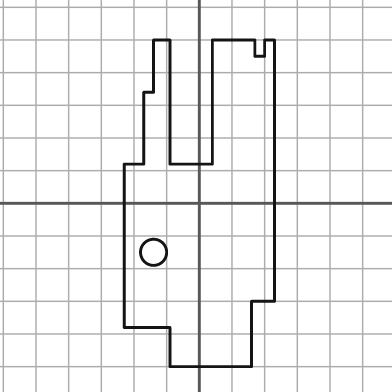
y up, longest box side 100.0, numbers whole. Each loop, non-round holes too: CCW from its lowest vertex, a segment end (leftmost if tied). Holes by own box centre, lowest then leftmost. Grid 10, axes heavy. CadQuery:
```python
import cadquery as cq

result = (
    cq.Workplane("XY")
    .moveTo(-9.0, -50.0)
    .lineTo(16.0, -50.0)
    .lineTo(16.0, -30.0)
    .lineTo(23.0, -30.0)
    .lineTo(23.0, 50.0)
    .lineTo(20.0, 50.0)
    .lineTo(20.0, 45.0)
    .lineTo(17.0, 45.0)
    .lineTo(17.0, 50.0)
    .lineTo(4.0, 50.0)
    .lineTo(4.0, 12.0)
    .lineTo(-9.0, 12.0)
    .lineTo(-9.0, 50.0)
    .lineTo(-14.0, 50.0)
    .lineTo(-14.0, 34.0)
    .lineTo(-17.0, 34.0)
    .lineTo(-17.0, 12.0)
    .lineTo(-23.0, 12.0)
    .lineTo(-23.0, -38.0)
    .lineTo(-9.0, -38.0)
    .close()
    .moveTo(-14.0, -15.0)
    .circle(4.0)
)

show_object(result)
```